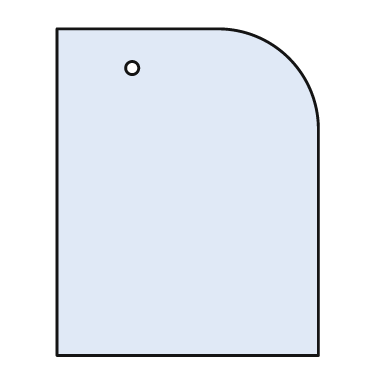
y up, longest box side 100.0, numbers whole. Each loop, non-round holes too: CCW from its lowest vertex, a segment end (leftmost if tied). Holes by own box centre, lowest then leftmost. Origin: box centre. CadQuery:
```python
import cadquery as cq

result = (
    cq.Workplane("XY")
    .moveTo(-40.0, -50.0)
    .lineTo(40.0, -50.0)
    .lineTo(40.0, 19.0)
    .threePointArc((31.0, 41.0), (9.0, 50.0))
    .lineTo(-40.0, 50.0)
    .close()
    .moveTo(-17.0, 38.0)
    .circle(2.0)
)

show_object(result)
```